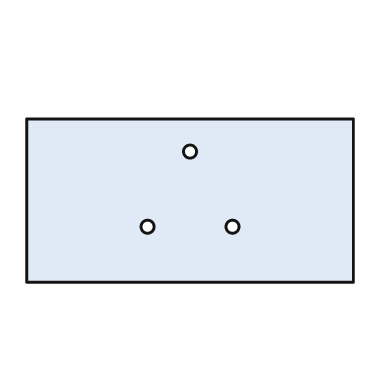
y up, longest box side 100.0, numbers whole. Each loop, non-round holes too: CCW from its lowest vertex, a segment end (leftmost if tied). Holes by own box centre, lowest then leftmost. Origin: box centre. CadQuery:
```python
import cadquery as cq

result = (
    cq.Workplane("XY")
    .moveTo(-50.0, -25.0)
    .lineTo(50.0, -25.0)
    .lineTo(50.0, 25.0)
    .lineTo(-50.0, 25.0)
    .close()
    .moveTo(-13.0, -8.0)
    .circle(2.0)
    .moveTo(13.0, -8.0)
    .circle(2.0)
    .moveTo(0.0, 15.0)
    .circle(2.0)
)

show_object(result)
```